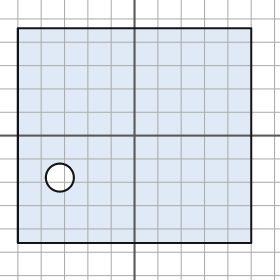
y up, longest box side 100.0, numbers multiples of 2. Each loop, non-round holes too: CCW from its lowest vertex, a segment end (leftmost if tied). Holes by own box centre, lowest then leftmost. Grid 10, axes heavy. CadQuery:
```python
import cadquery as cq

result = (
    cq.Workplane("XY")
    .moveTo(-50.0, -46.0)
    .lineTo(50.0, -46.0)
    .lineTo(50.0, 46.0)
    .lineTo(-50.0, 46.0)
    .close()
    .moveTo(-32.0, -18.0)
    .circle(6.0)
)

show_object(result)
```